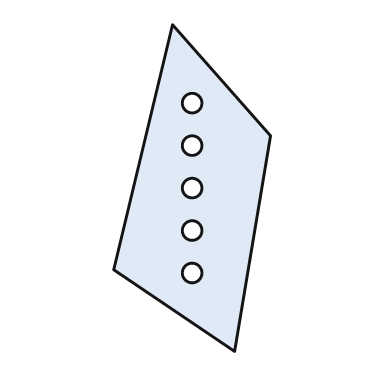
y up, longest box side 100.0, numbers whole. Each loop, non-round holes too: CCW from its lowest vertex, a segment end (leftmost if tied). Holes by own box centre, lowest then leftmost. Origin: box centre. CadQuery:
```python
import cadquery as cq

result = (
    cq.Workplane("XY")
    .moveTo(13.0, -50.0)
    .lineTo(24.0, 16.0)
    .lineTo(-6.0, 50.0)
    .lineTo(-24.0, -25.0)
    .close()
    .moveTo(0.0, -26.0)
    .circle(3.0)
    .moveTo(0.0, -13.0)
    .circle(3.0)
    .moveTo(0.0, 0.0)
    .circle(3.0)
    .moveTo(0.0, 13.0)
    .circle(3.0)
    .moveTo(0.0, 26.0)
    .circle(3.0)
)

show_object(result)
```